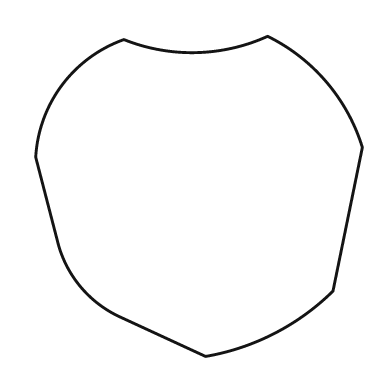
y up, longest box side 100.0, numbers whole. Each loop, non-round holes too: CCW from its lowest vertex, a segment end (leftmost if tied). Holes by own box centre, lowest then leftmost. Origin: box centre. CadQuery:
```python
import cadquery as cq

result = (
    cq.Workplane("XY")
    .moveTo(2.0, -49.0)
    .threePointArc((23.0, -42.0), (41.0, -29.0))
    .lineTo(50.0, 15.0)
    .threePointArc((39.0, 35.0), (21.0, 49.0))
    .threePointArc((-1.0, 44.0), (-23.0, 48.0))
    .threePointArc((-42.0, 34.0), (-50.0, 12.0))
    .lineTo(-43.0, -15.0)
    .threePointArc((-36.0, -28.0), (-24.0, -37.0))
    .close()
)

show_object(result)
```